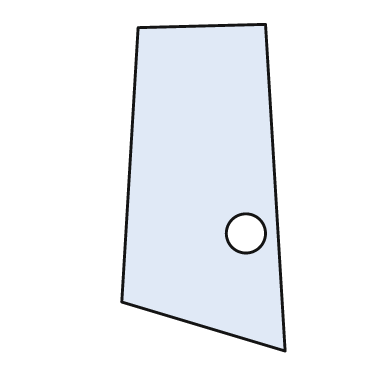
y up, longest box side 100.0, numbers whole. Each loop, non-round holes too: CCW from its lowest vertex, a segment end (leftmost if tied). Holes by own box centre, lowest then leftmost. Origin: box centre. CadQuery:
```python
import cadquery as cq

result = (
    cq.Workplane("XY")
    .moveTo(25.0, -50.0)
    .lineTo(19.0, 50.0)
    .lineTo(-20.0, 49.0)
    .lineTo(-25.0, -35.0)
    .close()
    .moveTo(13.0, -14.0)
    .circle(6.0)
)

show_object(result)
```